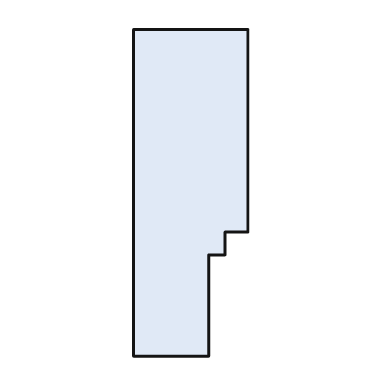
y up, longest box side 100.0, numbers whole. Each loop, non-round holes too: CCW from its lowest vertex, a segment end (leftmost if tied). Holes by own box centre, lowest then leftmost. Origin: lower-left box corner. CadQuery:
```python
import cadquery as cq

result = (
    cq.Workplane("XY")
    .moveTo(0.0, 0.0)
    .lineTo(23.0, 0.0)
    .lineTo(23.0, 31.0)
    .lineTo(28.0, 31.0)
    .lineTo(28.0, 38.0)
    .lineTo(35.0, 38.0)
    .lineTo(35.0, 100.0)
    .lineTo(0.0, 100.0)
    .close()
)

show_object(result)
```